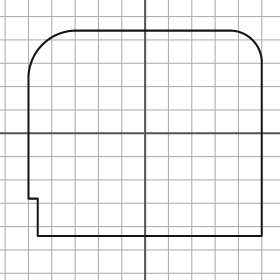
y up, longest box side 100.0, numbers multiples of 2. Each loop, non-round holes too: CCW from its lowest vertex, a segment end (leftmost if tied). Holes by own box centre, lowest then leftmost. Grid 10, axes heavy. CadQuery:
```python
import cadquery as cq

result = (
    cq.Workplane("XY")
    .moveTo(-46.0, -44.0)
    .lineTo(50.0, -44.0)
    .lineTo(50.0, 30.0)
    .threePointArc((46.0, 40.0), (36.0, 44.0))
    .lineTo(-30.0, 44.0)
    .threePointArc((-44.0, 38.0), (-50.0, 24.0))
    .lineTo(-50.0, -28.0)
    .lineTo(-46.0, -28.0)
    .close()
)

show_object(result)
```